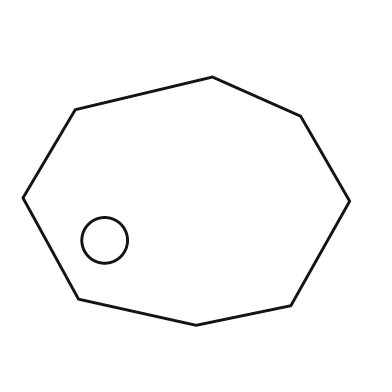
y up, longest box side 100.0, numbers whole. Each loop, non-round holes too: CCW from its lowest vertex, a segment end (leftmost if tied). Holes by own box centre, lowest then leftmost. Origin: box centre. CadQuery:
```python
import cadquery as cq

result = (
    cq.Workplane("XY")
    .moveTo(3.0, -38.0)
    .lineTo(32.0, -32.0)
    .lineTo(50.0, 0.0)
    .lineTo(35.0, 26.0)
    .lineTo(8.0, 38.0)
    .lineTo(-34.0, 28.0)
    .lineTo(-50.0, 1.0)
    .lineTo(-33.0, -30.0)
    .close()
    .moveTo(-25.0, -12.0)
    .circle(7.0)
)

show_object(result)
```